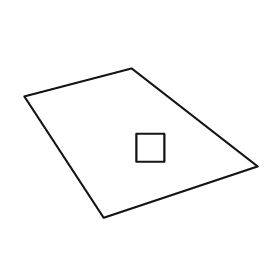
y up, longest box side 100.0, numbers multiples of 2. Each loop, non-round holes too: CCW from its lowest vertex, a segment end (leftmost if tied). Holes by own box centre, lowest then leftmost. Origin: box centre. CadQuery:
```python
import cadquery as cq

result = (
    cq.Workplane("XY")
    .moveTo(-16.0, -32.0)
    .lineTo(50.0, -10.0)
    .lineTo(-4.0, 32.0)
    .lineTo(-50.0, 20.0)
    .close()
    .moveTo(-2.0, -8.0)
    .lineTo(10.0, -8.0)
    .lineTo(10.0, 4.0)
    .lineTo(-2.0, 4.0)
    .close()
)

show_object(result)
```